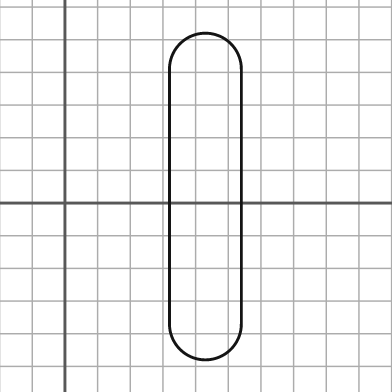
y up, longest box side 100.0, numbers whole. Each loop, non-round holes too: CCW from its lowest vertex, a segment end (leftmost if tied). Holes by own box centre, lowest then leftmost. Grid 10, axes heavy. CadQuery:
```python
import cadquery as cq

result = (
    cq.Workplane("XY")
    .moveTo(32.0, -37.0)
    .threePointArc((43.0, -48.0), (54.0, -37.0))
    .lineTo(54.0, 41.0)
    .threePointArc((43.0, 52.0), (32.0, 41.0))
    .close()
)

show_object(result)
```